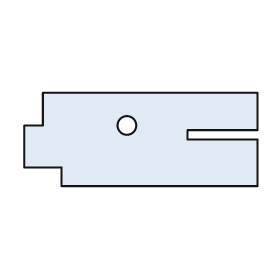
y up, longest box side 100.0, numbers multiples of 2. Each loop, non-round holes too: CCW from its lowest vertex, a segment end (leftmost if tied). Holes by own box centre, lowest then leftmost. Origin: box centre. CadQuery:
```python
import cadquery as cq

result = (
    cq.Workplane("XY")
    .moveTo(-34.0, -20.0)
    .lineTo(50.0, -20.0)
    .lineTo(50.0, 0.0)
    .lineTo(20.0, 0.0)
    .lineTo(20.0, 4.0)
    .lineTo(50.0, 4.0)
    .lineTo(50.0, 20.0)
    .lineTo(-42.0, 20.0)
    .lineTo(-42.0, 6.0)
    .lineTo(-50.0, 6.0)
    .lineTo(-50.0, -12.0)
    .lineTo(-34.0, -12.0)
    .close()
    .moveTo(-6.0, 6.0)
    .circle(4.0)
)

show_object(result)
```